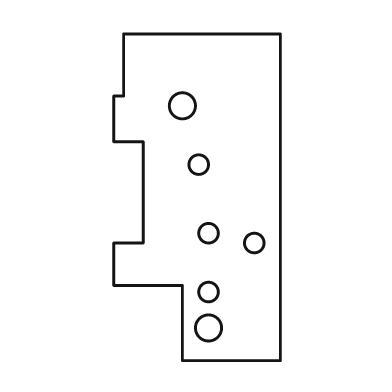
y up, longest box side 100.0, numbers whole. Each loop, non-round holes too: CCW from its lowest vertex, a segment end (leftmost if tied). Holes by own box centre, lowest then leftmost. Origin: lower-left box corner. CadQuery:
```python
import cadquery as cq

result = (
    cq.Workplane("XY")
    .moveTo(21.0, 0.0)
    .lineTo(51.0, 0.0)
    .lineTo(51.0, 100.0)
    .lineTo(3.0, 100.0)
    .lineTo(3.0, 81.0)
    .lineTo(0.0, 81.0)
    .lineTo(0.0, 67.0)
    .lineTo(9.0, 67.0)
    .lineTo(9.0, 36.0)
    .lineTo(0.0, 36.0)
    .lineTo(0.0, 23.0)
    .lineTo(21.0, 23.0)
    .close()
    .moveTo(29.0, 10.0)
    .circle(4.0)
    .moveTo(29.0, 21.0)
    .circle(3.0)
    .moveTo(43.0, 36.0)
    .circle(3.0)
    .moveTo(29.0, 39.0)
    .circle(3.0)
    .moveTo(26.0, 60.0)
    .circle(3.0)
    .moveTo(21.0, 78.0)
    .circle(4.0)
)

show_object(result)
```